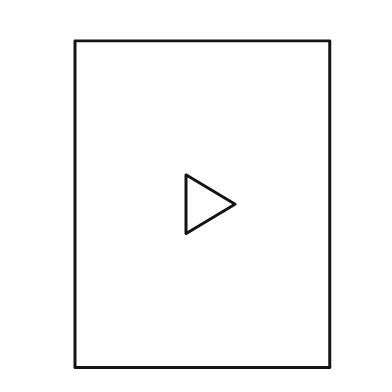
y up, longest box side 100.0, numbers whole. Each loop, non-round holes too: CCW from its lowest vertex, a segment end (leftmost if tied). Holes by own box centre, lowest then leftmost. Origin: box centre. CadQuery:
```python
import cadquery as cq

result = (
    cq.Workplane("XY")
    .moveTo(-39.0, -50.0)
    .lineTo(39.0, -50.0)
    .lineTo(39.0, 50.0)
    .lineTo(-39.0, 50.0)
    .close()
    .moveTo(-5.0, -9.0)
    .lineTo(10.0, 0.0)
    .lineTo(-5.0, 9.0)
    .close()
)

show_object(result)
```